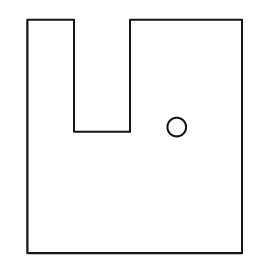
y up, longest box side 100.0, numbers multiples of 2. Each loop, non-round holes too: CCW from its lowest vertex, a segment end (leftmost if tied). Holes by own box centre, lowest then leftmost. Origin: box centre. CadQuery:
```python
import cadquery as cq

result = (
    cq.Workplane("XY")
    .moveTo(-46.0, -50.0)
    .lineTo(46.0, -50.0)
    .lineTo(46.0, 50.0)
    .lineTo(-2.0, 50.0)
    .lineTo(-2.0, 2.0)
    .lineTo(-26.0, 2.0)
    .lineTo(-26.0, 50.0)
    .lineTo(-46.0, 50.0)
    .close()
    .moveTo(18.0, 4.0)
    .circle(4.0)
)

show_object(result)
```